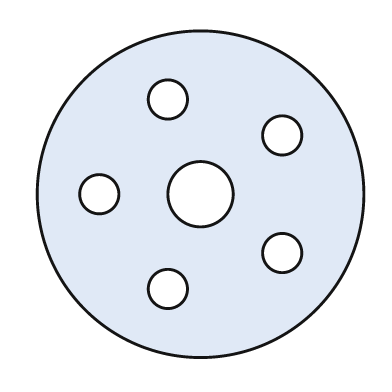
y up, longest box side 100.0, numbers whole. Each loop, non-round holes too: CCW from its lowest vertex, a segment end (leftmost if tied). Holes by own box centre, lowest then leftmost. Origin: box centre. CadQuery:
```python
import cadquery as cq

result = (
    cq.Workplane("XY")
    .moveTo(0.0, 0.0)
    .circle(50.0)
    .moveTo(-10.0, -29.0)
    .circle(6.0)
    .moveTo(25.0, -18.0)
    .circle(6.0)
    .moveTo(-31.0, 0.0)
    .circle(6.0)
    .moveTo(0.0, 0.0)
    .circle(10.0)
    .moveTo(25.0, 18.0)
    .circle(6.0)
    .moveTo(-10.0, 29.0)
    .circle(6.0)
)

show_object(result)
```